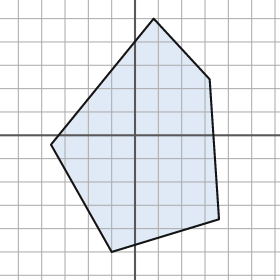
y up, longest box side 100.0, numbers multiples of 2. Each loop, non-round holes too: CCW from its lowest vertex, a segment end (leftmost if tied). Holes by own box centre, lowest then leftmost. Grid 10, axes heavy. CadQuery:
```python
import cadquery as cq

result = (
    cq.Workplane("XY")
    .moveTo(-10.0, -50.0)
    .lineTo(36.0, -36.0)
    .lineTo(32.0, 24.0)
    .lineTo(8.0, 50.0)
    .lineTo(-36.0, -4.0)
    .close()
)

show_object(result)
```